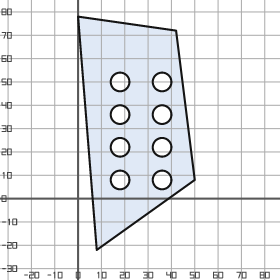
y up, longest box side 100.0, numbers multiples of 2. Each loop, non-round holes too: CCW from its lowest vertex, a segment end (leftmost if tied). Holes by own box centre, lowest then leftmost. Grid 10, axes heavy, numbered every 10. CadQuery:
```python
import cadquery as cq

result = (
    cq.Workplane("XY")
    .moveTo(8.0, -22.0)
    .lineTo(50.0, 8.0)
    .lineTo(42.0, 72.0)
    .lineTo(0.0, 78.0)
    .close()
    .moveTo(18.0, 8.0)
    .circle(4.0)
    .moveTo(36.0, 8.0)
    .circle(4.0)
    .moveTo(18.0, 22.0)
    .circle(4.0)
    .moveTo(36.0, 22.0)
    .circle(4.0)
    .moveTo(18.0, 36.0)
    .circle(4.0)
    .moveTo(36.0, 36.0)
    .circle(4.0)
    .moveTo(18.0, 50.0)
    .circle(4.0)
    .moveTo(36.0, 50.0)
    .circle(4.0)
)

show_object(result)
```